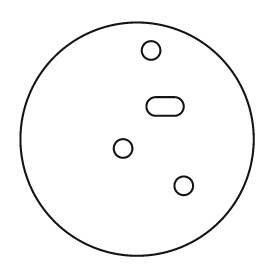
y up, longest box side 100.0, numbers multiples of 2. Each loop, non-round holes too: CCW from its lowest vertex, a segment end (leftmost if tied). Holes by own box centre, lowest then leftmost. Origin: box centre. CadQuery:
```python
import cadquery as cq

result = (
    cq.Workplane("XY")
    .moveTo(0.0, 0.0)
    .circle(50.0)
    .moveTo(20.0, -20.0)
    .circle(4.0)
    .moveTo(-6.0, -4.0)
    .circle(4.0)
    .moveTo(8.0, 10.0)
    .lineTo(16.0, 10.0)
    .threePointArc((20.0, 14.0), (16.0, 18.0))
    .lineTo(8.0, 18.0)
    .threePointArc((4.0, 14.0), (8.0, 10.0))
    .close()
    .moveTo(6.0, 38.0)
    .circle(4.0)
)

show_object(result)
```